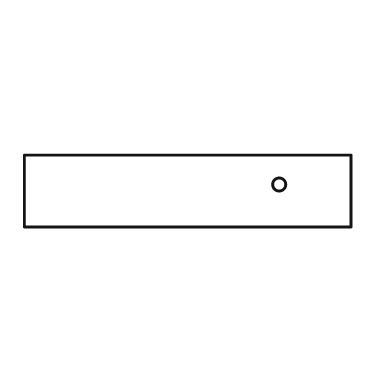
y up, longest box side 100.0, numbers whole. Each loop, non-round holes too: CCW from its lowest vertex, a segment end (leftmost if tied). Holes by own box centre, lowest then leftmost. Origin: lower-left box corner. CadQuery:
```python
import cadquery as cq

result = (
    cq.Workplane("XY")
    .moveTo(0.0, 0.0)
    .lineTo(100.0, 0.0)
    .lineTo(100.0, 22.0)
    .lineTo(0.0, 22.0)
    .close()
    .moveTo(78.0, 13.0)
    .circle(2.0)
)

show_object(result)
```